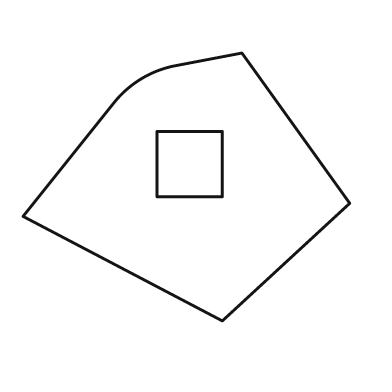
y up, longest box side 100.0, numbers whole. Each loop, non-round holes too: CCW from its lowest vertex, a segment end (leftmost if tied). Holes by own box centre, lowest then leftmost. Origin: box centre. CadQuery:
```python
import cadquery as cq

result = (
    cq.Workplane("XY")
    .moveTo(11.0, -41.0)
    .lineTo(50.0, -5.0)
    .lineTo(17.0, 41.0)
    .lineTo(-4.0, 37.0)
    .threePointArc((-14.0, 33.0), (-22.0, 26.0))
    .lineTo(-50.0, -9.0)
    .close()
    .moveTo(-9.0, -3.0)
    .lineTo(11.0, -3.0)
    .lineTo(11.0, 17.0)
    .lineTo(-9.0, 17.0)
    .close()
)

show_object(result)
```